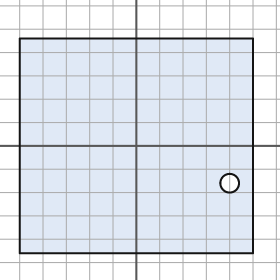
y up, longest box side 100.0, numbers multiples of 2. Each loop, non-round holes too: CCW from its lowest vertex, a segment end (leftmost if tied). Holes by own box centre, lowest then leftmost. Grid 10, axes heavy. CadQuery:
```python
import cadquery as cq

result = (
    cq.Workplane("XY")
    .moveTo(-50.0, -46.0)
    .lineTo(50.0, -46.0)
    .lineTo(50.0, 46.0)
    .lineTo(-50.0, 46.0)
    .close()
    .moveTo(40.0, -16.0)
    .circle(4.0)
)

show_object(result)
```